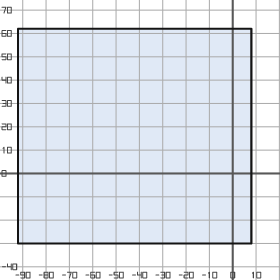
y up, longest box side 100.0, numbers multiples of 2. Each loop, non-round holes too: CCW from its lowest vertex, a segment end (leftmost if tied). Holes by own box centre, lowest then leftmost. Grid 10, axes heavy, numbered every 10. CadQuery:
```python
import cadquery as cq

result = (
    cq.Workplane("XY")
    .moveTo(-92.0, -30.0)
    .lineTo(8.0, -30.0)
    .lineTo(8.0, 62.0)
    .lineTo(-92.0, 62.0)
    .close()
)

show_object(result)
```